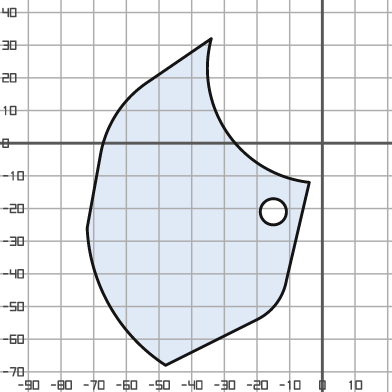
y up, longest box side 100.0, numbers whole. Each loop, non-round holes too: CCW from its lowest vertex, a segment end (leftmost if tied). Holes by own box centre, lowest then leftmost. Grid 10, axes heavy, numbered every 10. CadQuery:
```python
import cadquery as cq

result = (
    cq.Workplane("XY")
    .moveTo(-48.0, -68.0)
    .lineTo(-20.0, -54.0)
    .threePointArc((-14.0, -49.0), (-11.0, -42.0))
    .lineTo(-4.0, -12.0)
    .threePointArc((-29.0, 3.0), (-34.0, 32.0))
    .lineTo(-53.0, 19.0)
    .threePointArc((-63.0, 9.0), (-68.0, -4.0))
    .lineTo(-72.0, -26.0)
    .threePointArc((-65.0, -50.0), (-48.0, -68.0))
    .close()
    .moveTo(-15.0, -21.0)
    .circle(4.0)
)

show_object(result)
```